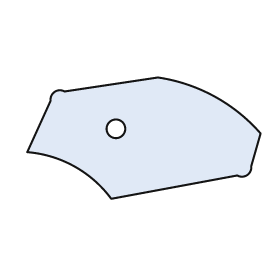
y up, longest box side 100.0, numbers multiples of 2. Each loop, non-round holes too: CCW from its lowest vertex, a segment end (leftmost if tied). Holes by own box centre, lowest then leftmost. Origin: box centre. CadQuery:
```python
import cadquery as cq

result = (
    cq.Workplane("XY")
    .moveTo(-14.0, -26.0)
    .lineTo(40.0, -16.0)
    .threePointArc((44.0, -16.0), (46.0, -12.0))
    .lineTo(50.0, 2.0)
    .threePointArc((30.0, 18.0), (6.0, 26.0))
    .lineTo(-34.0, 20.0)
    .threePointArc((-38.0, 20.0), (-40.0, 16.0))
    .lineTo(-50.0, -6.0)
    .threePointArc((-30.0, -12.0), (-14.0, -26.0))
    .close()
    .moveTo(-12.0, 4.0)
    .circle(4.0)
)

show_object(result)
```